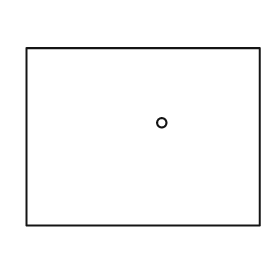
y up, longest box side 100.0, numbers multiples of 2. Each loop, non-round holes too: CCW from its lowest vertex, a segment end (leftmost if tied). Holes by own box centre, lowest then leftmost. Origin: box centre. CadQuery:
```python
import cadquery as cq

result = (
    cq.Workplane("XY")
    .moveTo(-50.0, -38.0)
    .lineTo(50.0, -38.0)
    .lineTo(50.0, 38.0)
    .lineTo(-50.0, 38.0)
    .close()
    .moveTo(8.0, 6.0)
    .circle(2.0)
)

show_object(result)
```